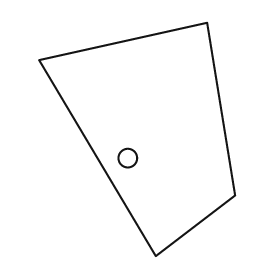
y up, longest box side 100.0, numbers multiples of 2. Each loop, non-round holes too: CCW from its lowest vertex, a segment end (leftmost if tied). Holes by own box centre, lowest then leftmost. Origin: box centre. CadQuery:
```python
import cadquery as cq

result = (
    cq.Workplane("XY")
    .moveTo(8.0, -50.0)
    .lineTo(42.0, -24.0)
    .lineTo(30.0, 50.0)
    .lineTo(-42.0, 34.0)
    .close()
    .moveTo(-4.0, -8.0)
    .circle(4.0)
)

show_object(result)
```